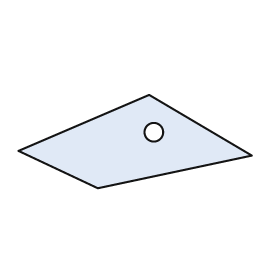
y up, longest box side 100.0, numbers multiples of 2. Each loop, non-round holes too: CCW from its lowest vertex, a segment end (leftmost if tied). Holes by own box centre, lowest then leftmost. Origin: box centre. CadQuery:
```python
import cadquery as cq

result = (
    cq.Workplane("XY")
    .moveTo(-16.0, -20.0)
    .lineTo(50.0, -6.0)
    .lineTo(6.0, 20.0)
    .lineTo(-50.0, -4.0)
    .close()
    .moveTo(8.0, 4.0)
    .circle(4.0)
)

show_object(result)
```